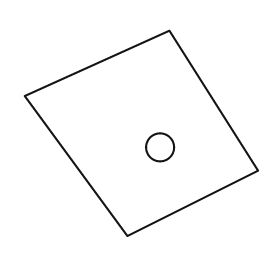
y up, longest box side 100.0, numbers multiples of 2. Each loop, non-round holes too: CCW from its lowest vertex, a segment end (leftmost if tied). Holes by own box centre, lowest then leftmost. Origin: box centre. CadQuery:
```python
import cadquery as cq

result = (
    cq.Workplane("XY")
    .moveTo(-6.0, -44.0)
    .lineTo(50.0, -16.0)
    .lineTo(12.0, 44.0)
    .lineTo(-50.0, 16.0)
    .close()
    .moveTo(8.0, -6.0)
    .circle(6.0)
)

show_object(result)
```